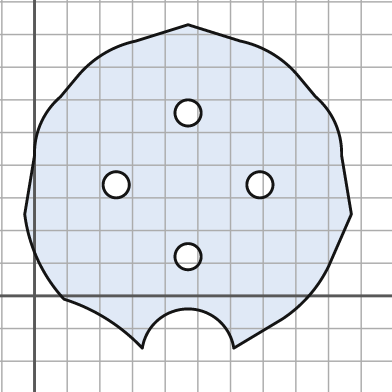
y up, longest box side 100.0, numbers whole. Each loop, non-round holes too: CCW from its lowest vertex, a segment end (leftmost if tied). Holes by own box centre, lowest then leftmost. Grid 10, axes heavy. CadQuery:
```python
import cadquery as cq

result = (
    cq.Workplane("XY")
    .moveTo(33.0, -16.0)
    .threePointArc((47.0, -4.0), (61.0, -16.0))
    .lineTo(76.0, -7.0)
    .threePointArc((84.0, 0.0), (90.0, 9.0))
    .lineTo(97.0, 25.0)
    .lineTo(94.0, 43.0)
    .threePointArc((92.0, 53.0), (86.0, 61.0))
    .lineTo(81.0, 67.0)
    .threePointArc((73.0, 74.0), (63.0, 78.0))
    .lineTo(47.0, 83.0)
    .lineTo(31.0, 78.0)
    .threePointArc((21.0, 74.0), (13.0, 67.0))
    .lineTo(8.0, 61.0)
    .threePointArc((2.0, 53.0), (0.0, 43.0))
    .lineTo(-3.0, 25.0)
    .threePointArc((1.0, 11.0), (9.0, -1.0))
    .threePointArc((22.0, -7.0), (33.0, -16.0))
    .close()
    .moveTo(47.0, 12.0)
    .circle(4.0)
    .moveTo(25.0, 34.0)
    .circle(4.0)
    .moveTo(69.0, 34.0)
    .circle(4.0)
    .moveTo(47.0, 56.0)
    .circle(4.0)
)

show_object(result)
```